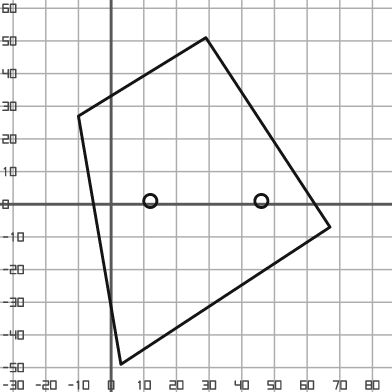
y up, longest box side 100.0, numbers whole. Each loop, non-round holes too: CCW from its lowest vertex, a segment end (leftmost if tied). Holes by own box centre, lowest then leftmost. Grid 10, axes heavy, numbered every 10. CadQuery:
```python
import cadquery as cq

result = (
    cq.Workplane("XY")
    .moveTo(3.0, -49.0)
    .lineTo(67.0, -7.0)
    .lineTo(29.0, 51.0)
    .lineTo(-10.0, 27.0)
    .close()
    .moveTo(12.0, 1.0)
    .circle(2.0)
    .moveTo(46.0, 1.0)
    .circle(2.0)
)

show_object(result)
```